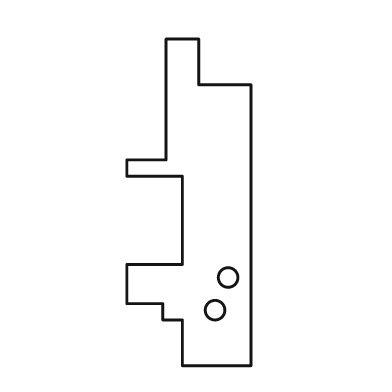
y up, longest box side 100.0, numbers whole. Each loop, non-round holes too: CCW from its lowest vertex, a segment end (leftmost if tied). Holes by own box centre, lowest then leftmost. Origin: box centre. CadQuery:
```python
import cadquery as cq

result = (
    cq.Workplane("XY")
    .moveTo(-2.0, -50.0)
    .lineTo(19.0, -50.0)
    .lineTo(19.0, 36.0)
    .lineTo(3.0, 36.0)
    .lineTo(3.0, 50.0)
    .lineTo(-7.0, 50.0)
    .lineTo(-7.0, 13.0)
    .lineTo(-19.0, 13.0)
    .lineTo(-19.0, 8.0)
    .lineTo(-2.0, 8.0)
    .lineTo(-2.0, -19.0)
    .lineTo(-19.0, -19.0)
    .lineTo(-19.0, -31.0)
    .lineTo(-8.0, -31.0)
    .lineTo(-8.0, -36.0)
    .lineTo(-2.0, -36.0)
    .close()
    .moveTo(8.0, -33.0)
    .circle(3.0)
    .moveTo(12.0, -23.0)
    .circle(3.0)
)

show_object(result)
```